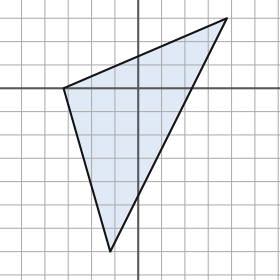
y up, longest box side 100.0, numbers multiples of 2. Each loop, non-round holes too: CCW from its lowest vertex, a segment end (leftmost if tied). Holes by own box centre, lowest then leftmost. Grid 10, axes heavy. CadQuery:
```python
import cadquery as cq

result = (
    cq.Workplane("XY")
    .moveTo(-12.0, -70.0)
    .lineTo(38.0, 30.0)
    .lineTo(-32.0, 0.0)
    .close()
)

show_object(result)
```